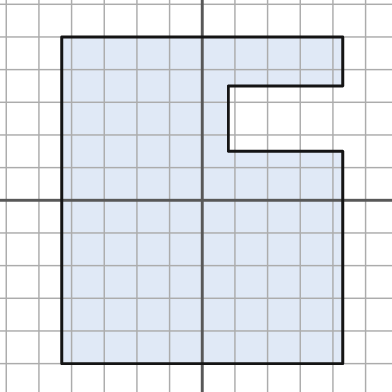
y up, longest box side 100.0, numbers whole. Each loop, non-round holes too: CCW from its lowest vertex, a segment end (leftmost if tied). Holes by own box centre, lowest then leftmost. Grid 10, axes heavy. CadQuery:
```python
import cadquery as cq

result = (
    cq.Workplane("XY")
    .moveTo(-43.0, -50.0)
    .lineTo(43.0, -50.0)
    .lineTo(43.0, 15.0)
    .lineTo(8.0, 15.0)
    .lineTo(8.0, 35.0)
    .lineTo(43.0, 35.0)
    .lineTo(43.0, 50.0)
    .lineTo(-43.0, 50.0)
    .close()
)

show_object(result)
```